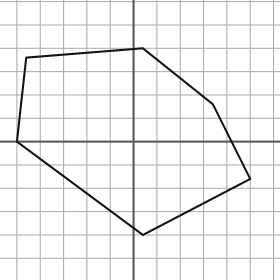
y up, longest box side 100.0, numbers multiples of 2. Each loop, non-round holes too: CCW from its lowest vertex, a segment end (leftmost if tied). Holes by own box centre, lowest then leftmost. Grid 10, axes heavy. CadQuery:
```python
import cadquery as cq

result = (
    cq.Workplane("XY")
    .moveTo(4.0, -40.0)
    .lineTo(50.0, -16.0)
    .lineTo(34.0, 16.0)
    .lineTo(4.0, 40.0)
    .lineTo(-46.0, 36.0)
    .lineTo(-50.0, 0.0)
    .close()
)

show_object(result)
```